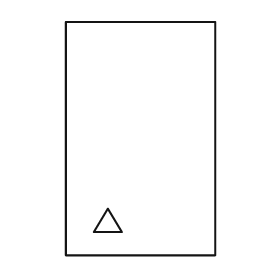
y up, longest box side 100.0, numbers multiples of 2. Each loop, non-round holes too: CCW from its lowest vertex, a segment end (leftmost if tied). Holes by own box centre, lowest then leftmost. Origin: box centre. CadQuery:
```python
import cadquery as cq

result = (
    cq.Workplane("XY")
    .moveTo(-32.0, -50.0)
    .lineTo(32.0, -50.0)
    .lineTo(32.0, 50.0)
    .lineTo(-32.0, 50.0)
    .close()
    .moveTo(-20.0, -40.0)
    .lineTo(-8.0, -40.0)
    .lineTo(-14.0, -30.0)
    .close()
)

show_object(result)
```